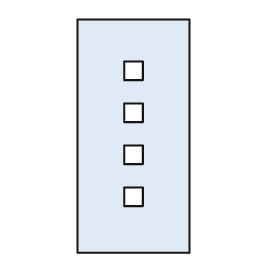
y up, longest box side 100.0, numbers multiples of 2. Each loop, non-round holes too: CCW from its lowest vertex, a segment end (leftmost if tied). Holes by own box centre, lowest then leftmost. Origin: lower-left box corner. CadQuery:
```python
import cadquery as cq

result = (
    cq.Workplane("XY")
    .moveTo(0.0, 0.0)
    .lineTo(48.0, 0.0)
    .lineTo(48.0, 100.0)
    .lineTo(0.0, 100.0)
    .close()
    .moveTo(20.0, 20.0)
    .lineTo(28.0, 20.0)
    .lineTo(28.0, 28.0)
    .lineTo(20.0, 28.0)
    .close()
    .moveTo(20.0, 38.0)
    .lineTo(28.0, 38.0)
    .lineTo(28.0, 46.0)
    .lineTo(20.0, 46.0)
    .close()
    .moveTo(20.0, 56.0)
    .lineTo(28.0, 56.0)
    .lineTo(28.0, 64.0)
    .lineTo(20.0, 64.0)
    .close()
    .moveTo(20.0, 74.0)
    .lineTo(28.0, 74.0)
    .lineTo(28.0, 82.0)
    .lineTo(20.0, 82.0)
    .close()
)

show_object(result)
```